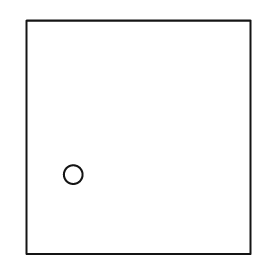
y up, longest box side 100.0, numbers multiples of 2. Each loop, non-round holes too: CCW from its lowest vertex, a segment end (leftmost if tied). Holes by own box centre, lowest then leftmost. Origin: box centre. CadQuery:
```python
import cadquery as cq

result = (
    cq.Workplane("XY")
    .moveTo(-48.0, -50.0)
    .lineTo(48.0, -50.0)
    .lineTo(48.0, 50.0)
    .lineTo(-48.0, 50.0)
    .close()
    .moveTo(-28.0, -16.0)
    .circle(4.0)
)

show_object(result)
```